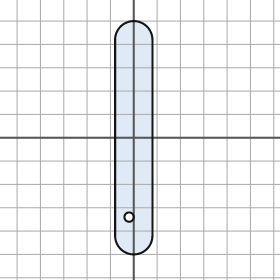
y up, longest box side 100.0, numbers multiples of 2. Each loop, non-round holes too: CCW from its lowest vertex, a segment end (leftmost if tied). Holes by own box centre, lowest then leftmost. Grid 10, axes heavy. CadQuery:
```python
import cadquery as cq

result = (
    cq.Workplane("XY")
    .moveTo(-8.0, -42.0)
    .threePointArc((0.0, -50.0), (8.0, -42.0))
    .lineTo(8.0, 42.0)
    .threePointArc((0.0, 50.0), (-8.0, 42.0))
    .close()
    .moveTo(-2.0, -34.0)
    .circle(2.0)
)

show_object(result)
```